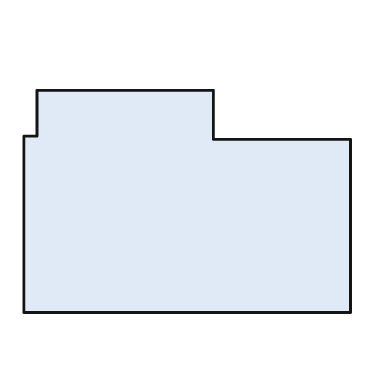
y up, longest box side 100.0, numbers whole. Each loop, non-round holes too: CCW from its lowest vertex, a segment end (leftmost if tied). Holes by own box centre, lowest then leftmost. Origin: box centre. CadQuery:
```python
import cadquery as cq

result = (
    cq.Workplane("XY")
    .moveTo(-50.0, -34.0)
    .lineTo(50.0, -34.0)
    .lineTo(50.0, 19.0)
    .lineTo(8.0, 19.0)
    .lineTo(8.0, 34.0)
    .lineTo(-46.0, 34.0)
    .lineTo(-46.0, 20.0)
    .lineTo(-50.0, 20.0)
    .close()
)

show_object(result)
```